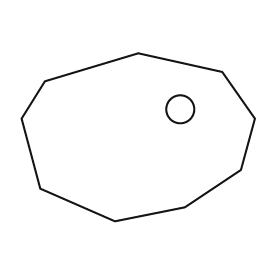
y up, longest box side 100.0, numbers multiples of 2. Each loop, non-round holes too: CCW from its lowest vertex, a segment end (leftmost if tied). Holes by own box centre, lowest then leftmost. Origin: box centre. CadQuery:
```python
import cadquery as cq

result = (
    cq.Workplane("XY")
    .moveTo(-10.0, -36.0)
    .lineTo(20.0, -30.0)
    .lineTo(44.0, -14.0)
    .lineTo(50.0, 8.0)
    .lineTo(36.0, 28.0)
    .lineTo(0.0, 36.0)
    .lineTo(-40.0, 24.0)
    .lineTo(-50.0, 8.0)
    .lineTo(-42.0, -22.0)
    .close()
    .moveTo(18.0, 12.0)
    .circle(6.0)
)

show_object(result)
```